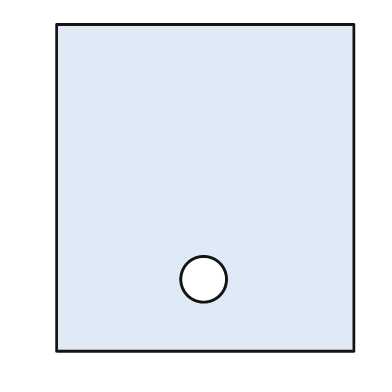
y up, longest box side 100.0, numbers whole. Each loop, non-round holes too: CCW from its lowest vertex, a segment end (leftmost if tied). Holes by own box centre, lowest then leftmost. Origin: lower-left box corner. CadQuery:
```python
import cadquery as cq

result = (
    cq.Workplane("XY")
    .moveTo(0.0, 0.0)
    .lineTo(91.0, 0.0)
    .lineTo(91.0, 100.0)
    .lineTo(0.0, 100.0)
    .close()
    .moveTo(45.0, 22.0)
    .circle(7.0)
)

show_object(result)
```